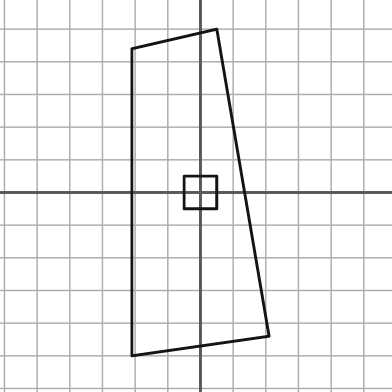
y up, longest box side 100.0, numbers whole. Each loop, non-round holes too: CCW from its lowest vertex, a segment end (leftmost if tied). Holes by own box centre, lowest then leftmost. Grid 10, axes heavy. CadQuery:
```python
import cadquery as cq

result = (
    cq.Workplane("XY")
    .moveTo(-21.0, -50.0)
    .lineTo(21.0, -44.0)
    .lineTo(5.0, 50.0)
    .lineTo(-21.0, 44.0)
    .close()
    .moveTo(-5.0, -5.0)
    .lineTo(5.0, -5.0)
    .lineTo(5.0, 5.0)
    .lineTo(-5.0, 5.0)
    .close()
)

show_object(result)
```